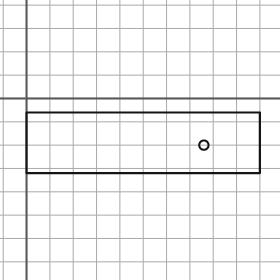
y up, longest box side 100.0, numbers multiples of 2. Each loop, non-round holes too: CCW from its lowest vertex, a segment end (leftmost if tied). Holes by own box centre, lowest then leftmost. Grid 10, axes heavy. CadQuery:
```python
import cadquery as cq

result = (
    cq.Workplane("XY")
    .moveTo(0.0, -32.0)
    .lineTo(100.0, -32.0)
    .lineTo(100.0, -6.0)
    .lineTo(0.0, -6.0)
    .close()
    .moveTo(76.0, -20.0)
    .circle(2.0)
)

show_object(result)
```